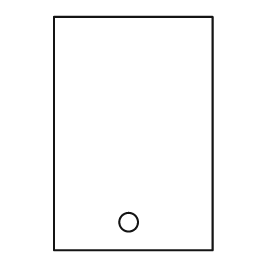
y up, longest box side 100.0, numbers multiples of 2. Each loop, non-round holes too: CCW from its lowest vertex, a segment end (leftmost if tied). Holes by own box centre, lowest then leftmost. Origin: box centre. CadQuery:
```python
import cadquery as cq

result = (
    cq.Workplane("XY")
    .moveTo(-34.0, -50.0)
    .lineTo(34.0, -50.0)
    .lineTo(34.0, 50.0)
    .lineTo(-34.0, 50.0)
    .close()
    .moveTo(-2.0, -38.0)
    .circle(4.0)
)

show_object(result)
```